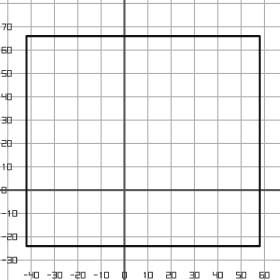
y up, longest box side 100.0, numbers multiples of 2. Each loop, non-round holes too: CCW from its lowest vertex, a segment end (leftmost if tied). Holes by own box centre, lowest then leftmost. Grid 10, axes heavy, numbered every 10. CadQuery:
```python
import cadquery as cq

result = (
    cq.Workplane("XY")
    .moveTo(-42.0, -24.0)
    .lineTo(58.0, -24.0)
    .lineTo(58.0, 66.0)
    .lineTo(-42.0, 66.0)
    .close()
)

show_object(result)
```